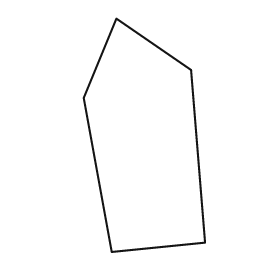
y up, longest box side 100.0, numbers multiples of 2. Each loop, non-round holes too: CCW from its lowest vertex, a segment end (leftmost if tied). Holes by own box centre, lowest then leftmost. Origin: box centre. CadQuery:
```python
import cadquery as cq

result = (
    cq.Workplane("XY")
    .moveTo(-14.0, -50.0)
    .lineTo(26.0, -46.0)
    .lineTo(20.0, 28.0)
    .lineTo(-12.0, 50.0)
    .lineTo(-26.0, 16.0)
    .close()
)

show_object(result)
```